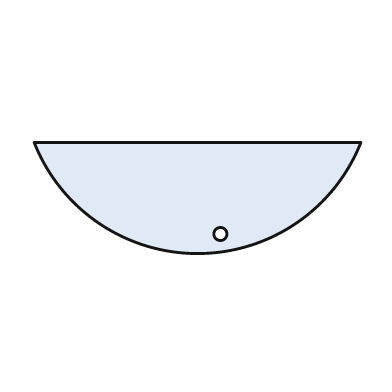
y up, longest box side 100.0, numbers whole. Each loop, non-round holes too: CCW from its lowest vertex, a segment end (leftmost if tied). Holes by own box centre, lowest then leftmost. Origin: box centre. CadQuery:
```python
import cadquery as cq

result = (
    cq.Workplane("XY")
    .moveTo(-50.0, 17.0)
    .threePointArc((0.0, -17.0), (50.0, 17.0))
    .close()
    .moveTo(7.0, -11.0)
    .circle(2.0)
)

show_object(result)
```